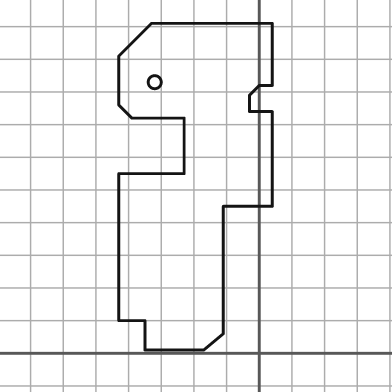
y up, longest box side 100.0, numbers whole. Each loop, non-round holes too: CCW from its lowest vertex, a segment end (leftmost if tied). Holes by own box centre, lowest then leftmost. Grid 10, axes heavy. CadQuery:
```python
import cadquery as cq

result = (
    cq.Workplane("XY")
    .moveTo(-35.0, 1.0)
    .lineTo(-17.0, 1.0)
    .lineTo(-11.0, 6.0)
    .lineTo(-11.0, 45.0)
    .lineTo(4.0, 45.0)
    .lineTo(4.0, 74.0)
    .lineTo(-3.0, 74.0)
    .lineTo(-3.0, 79.0)
    .lineTo(0.0, 82.0)
    .lineTo(4.0, 82.0)
    .lineTo(4.0, 101.0)
    .lineTo(-33.0, 101.0)
    .lineTo(-43.0, 91.0)
    .lineTo(-43.0, 76.0)
    .lineTo(-39.0, 72.0)
    .lineTo(-23.0, 72.0)
    .lineTo(-23.0, 55.0)
    .lineTo(-43.0, 55.0)
    .lineTo(-43.0, 10.0)
    .lineTo(-35.0, 10.0)
    .close()
    .moveTo(-32.0, 83.0)
    .circle(2.0)
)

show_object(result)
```